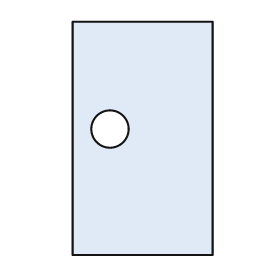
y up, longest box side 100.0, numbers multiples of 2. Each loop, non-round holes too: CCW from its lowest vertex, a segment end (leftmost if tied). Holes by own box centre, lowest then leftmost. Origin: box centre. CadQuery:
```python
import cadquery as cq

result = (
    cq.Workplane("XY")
    .moveTo(-30.0, -50.0)
    .lineTo(30.0, -50.0)
    .lineTo(30.0, 50.0)
    .lineTo(-30.0, 50.0)
    .close()
    .moveTo(-14.0, 4.0)
    .circle(8.0)
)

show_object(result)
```